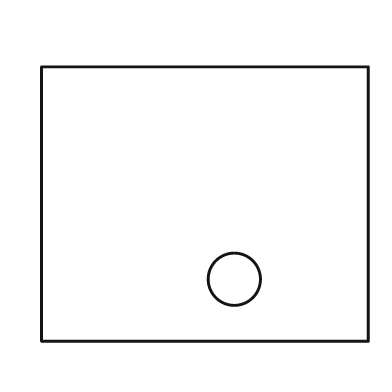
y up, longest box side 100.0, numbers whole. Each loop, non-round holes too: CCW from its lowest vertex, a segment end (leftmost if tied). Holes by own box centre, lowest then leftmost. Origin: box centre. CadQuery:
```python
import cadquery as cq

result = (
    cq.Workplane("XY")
    .moveTo(-50.0, -42.0)
    .lineTo(50.0, -42.0)
    .lineTo(50.0, 42.0)
    .lineTo(-50.0, 42.0)
    .close()
    .moveTo(9.0, -23.0)
    .circle(8.0)
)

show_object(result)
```